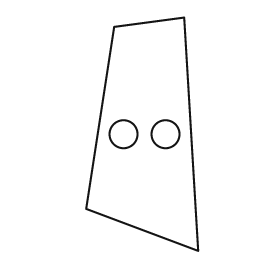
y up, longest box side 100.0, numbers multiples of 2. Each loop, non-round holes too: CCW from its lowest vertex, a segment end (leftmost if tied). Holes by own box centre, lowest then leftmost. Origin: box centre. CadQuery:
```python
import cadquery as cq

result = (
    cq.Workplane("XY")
    .moveTo(24.0, -50.0)
    .lineTo(18.0, 50.0)
    .lineTo(-12.0, 46.0)
    .lineTo(-24.0, -32.0)
    .close()
    .moveTo(-8.0, 0.0)
    .circle(6.0)
    .moveTo(10.0, 0.0)
    .circle(6.0)
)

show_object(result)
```